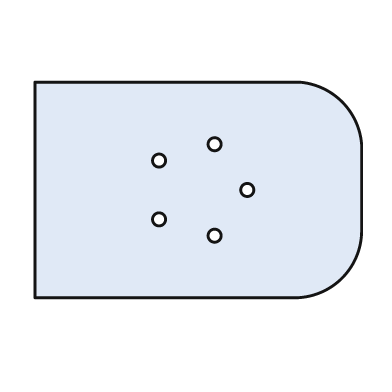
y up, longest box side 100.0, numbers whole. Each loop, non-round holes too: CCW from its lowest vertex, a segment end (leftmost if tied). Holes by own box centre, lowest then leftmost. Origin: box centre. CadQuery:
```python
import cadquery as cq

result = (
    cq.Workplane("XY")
    .moveTo(-50.0, -33.0)
    .lineTo(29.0, -33.0)
    .threePointArc((44.0, -27.0), (50.0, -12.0))
    .lineTo(50.0, 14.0)
    .threePointArc((44.0, 27.0), (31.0, 33.0))
    .lineTo(-50.0, 33.0)
    .close()
    .moveTo(5.0, -14.0)
    .circle(2.0)
    .moveTo(-12.0, -9.0)
    .circle(2.0)
    .moveTo(15.0, 0.0)
    .circle(2.0)
    .moveTo(-12.0, 9.0)
    .circle(2.0)
    .moveTo(5.0, 14.0)
    .circle(2.0)
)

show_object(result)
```